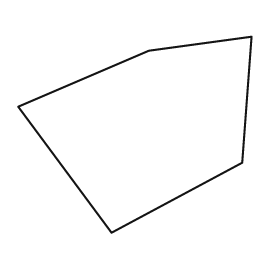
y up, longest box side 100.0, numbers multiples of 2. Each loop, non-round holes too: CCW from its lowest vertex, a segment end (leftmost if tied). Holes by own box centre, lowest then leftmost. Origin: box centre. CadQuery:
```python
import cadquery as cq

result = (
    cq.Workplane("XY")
    .moveTo(-10.0, -42.0)
    .lineTo(46.0, -12.0)
    .lineTo(50.0, 42.0)
    .lineTo(6.0, 36.0)
    .lineTo(-50.0, 12.0)
    .close()
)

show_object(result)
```